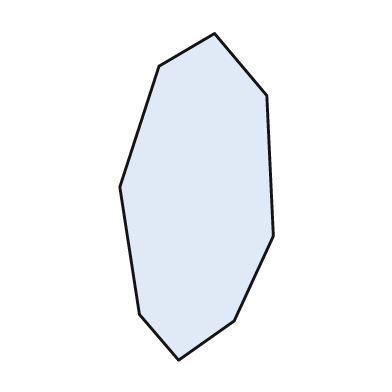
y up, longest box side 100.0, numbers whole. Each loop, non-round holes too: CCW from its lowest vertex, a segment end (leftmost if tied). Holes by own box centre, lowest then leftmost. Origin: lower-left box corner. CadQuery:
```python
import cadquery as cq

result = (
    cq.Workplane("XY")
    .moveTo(18.0, 0.0)
    .lineTo(35.0, 12.0)
    .lineTo(47.0, 38.0)
    .lineTo(45.0, 81.0)
    .lineTo(29.0, 100.0)
    .lineTo(12.0, 90.0)
    .lineTo(0.0, 53.0)
    .lineTo(6.0, 14.0)
    .close()
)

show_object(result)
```